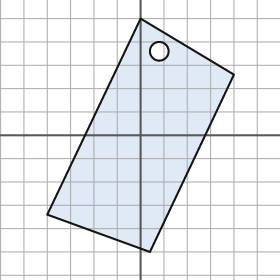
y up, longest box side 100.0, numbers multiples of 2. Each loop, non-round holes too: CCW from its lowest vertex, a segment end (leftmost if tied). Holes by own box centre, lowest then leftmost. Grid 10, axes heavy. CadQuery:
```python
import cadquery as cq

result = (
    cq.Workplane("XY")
    .moveTo(4.0, -50.0)
    .lineTo(40.0, 26.0)
    .lineTo(0.0, 50.0)
    .lineTo(-40.0, -34.0)
    .close()
    .moveTo(8.0, 36.0)
    .circle(4.0)
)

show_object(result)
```